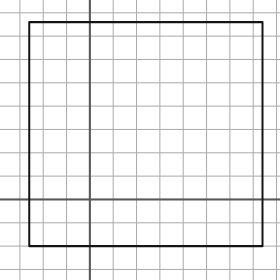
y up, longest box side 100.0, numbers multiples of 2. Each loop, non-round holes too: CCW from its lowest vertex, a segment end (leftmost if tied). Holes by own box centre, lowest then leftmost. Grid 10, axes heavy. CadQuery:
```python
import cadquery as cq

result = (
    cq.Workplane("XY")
    .moveTo(-26.0, -20.0)
    .lineTo(74.0, -20.0)
    .lineTo(74.0, 76.0)
    .lineTo(-26.0, 76.0)
    .close()
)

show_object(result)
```